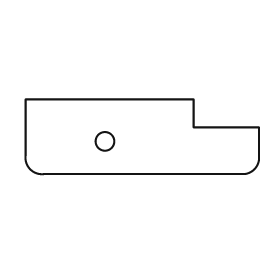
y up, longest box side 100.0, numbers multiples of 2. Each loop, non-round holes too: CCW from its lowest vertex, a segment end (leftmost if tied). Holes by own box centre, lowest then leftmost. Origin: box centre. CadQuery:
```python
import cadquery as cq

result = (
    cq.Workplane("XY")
    .moveTo(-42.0, -16.0)
    .lineTo(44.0, -16.0)
    .threePointArc((48.0, -14.0), (50.0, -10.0))
    .lineTo(50.0, 4.0)
    .lineTo(22.0, 4.0)
    .lineTo(22.0, 16.0)
    .lineTo(-50.0, 16.0)
    .lineTo(-50.0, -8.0)
    .threePointArc((-48.0, -14.0), (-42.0, -16.0))
    .close()
    .moveTo(-16.0, -2.0)
    .circle(4.0)
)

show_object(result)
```